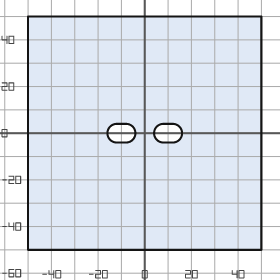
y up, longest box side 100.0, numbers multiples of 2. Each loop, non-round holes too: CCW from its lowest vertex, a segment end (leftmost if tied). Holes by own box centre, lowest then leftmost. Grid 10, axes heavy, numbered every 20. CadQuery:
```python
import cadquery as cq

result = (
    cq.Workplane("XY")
    .moveTo(-50.0, -50.0)
    .lineTo(50.0, -50.0)
    .lineTo(50.0, 50.0)
    .lineTo(-50.0, 50.0)
    .close()
    .moveTo(-12.0, -4.0)
    .lineTo(-8.0, -4.0)
    .threePointArc((-4.0, 0.0), (-8.0, 4.0))
    .lineTo(-12.0, 4.0)
    .threePointArc((-16.0, 0.0), (-12.0, -4.0))
    .close()
    .moveTo(8.0, -4.0)
    .lineTo(12.0, -4.0)
    .threePointArc((16.0, 0.0), (12.0, 4.0))
    .lineTo(8.0, 4.0)
    .threePointArc((4.0, 0.0), (8.0, -4.0))
    .close()
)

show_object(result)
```